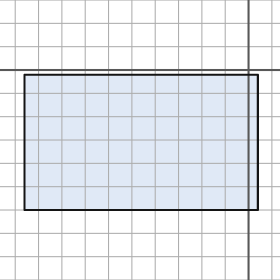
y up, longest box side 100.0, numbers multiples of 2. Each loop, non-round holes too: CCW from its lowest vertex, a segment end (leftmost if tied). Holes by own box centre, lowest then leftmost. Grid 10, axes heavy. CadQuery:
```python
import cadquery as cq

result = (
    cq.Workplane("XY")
    .moveTo(-96.0, -60.0)
    .lineTo(4.0, -60.0)
    .lineTo(4.0, -2.0)
    .lineTo(-96.0, -2.0)
    .close()
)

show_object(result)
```